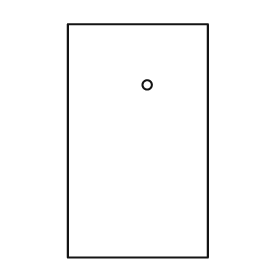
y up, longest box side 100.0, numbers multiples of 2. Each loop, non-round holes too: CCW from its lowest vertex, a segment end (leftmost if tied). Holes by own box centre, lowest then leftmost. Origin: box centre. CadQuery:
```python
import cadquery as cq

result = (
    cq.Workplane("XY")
    .moveTo(-30.0, -50.0)
    .lineTo(30.0, -50.0)
    .lineTo(30.0, 50.0)
    .lineTo(-30.0, 50.0)
    .close()
    .moveTo(4.0, 24.0)
    .circle(2.0)
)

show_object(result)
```